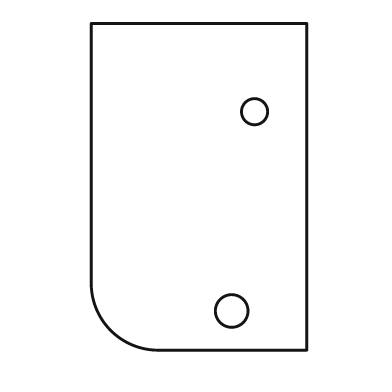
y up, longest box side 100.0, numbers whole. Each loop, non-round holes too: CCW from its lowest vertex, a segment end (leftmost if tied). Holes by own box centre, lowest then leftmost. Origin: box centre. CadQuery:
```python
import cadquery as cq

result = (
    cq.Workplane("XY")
    .moveTo(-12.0, -50.0)
    .lineTo(33.0, -50.0)
    .lineTo(33.0, 50.0)
    .lineTo(-33.0, 50.0)
    .lineTo(-33.0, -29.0)
    .threePointArc((-27.0, -44.0), (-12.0, -50.0))
    .close()
    .moveTo(10.0, -38.0)
    .circle(5.0)
    .moveTo(17.0, 23.0)
    .circle(4.0)
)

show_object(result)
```